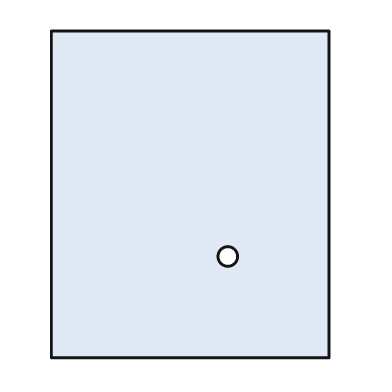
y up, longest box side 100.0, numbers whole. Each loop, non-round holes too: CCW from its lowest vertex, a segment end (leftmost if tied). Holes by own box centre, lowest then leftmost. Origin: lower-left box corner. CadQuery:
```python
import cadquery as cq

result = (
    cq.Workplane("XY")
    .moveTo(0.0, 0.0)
    .lineTo(85.0, 0.0)
    .lineTo(85.0, 100.0)
    .lineTo(0.0, 100.0)
    .close()
    .moveTo(54.0, 31.0)
    .circle(3.0)
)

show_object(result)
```